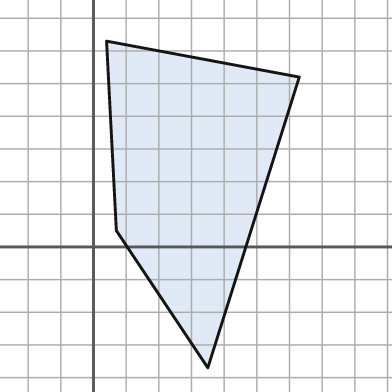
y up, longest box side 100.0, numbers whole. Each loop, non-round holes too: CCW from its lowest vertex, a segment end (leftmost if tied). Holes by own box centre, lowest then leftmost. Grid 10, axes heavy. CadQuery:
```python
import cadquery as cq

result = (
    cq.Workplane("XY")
    .moveTo(35.0, -37.0)
    .lineTo(63.0, 52.0)
    .lineTo(4.0, 63.0)
    .lineTo(7.0, 5.0)
    .close()
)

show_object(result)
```